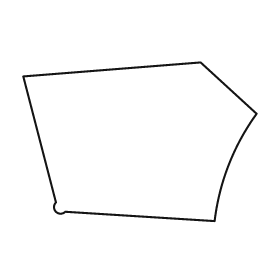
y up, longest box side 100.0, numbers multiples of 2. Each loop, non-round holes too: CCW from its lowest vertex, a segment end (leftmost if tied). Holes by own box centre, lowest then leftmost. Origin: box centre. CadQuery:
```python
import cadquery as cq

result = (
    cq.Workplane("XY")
    .moveTo(32.0, -34.0)
    .threePointArc((38.0, -10.0), (50.0, 12.0))
    .lineTo(26.0, 34.0)
    .lineTo(-50.0, 28.0)
    .lineTo(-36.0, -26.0)
    .threePointArc((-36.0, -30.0), (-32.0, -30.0))
    .close()
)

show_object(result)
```